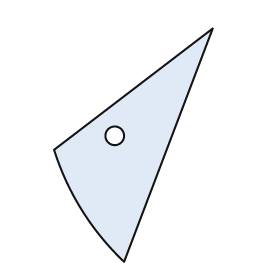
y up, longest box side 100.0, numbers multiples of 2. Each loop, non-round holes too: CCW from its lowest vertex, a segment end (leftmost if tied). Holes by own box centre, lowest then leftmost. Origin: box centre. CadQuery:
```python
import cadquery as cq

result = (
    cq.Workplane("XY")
    .moveTo(-4.0, -50.0)
    .lineTo(34.0, 50.0)
    .lineTo(-34.0, -2.0)
    .threePointArc((-22.0, -28.0), (-4.0, -50.0))
    .close()
    .moveTo(-8.0, 4.0)
    .circle(4.0)
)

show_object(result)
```